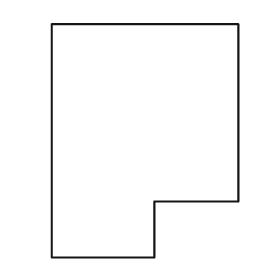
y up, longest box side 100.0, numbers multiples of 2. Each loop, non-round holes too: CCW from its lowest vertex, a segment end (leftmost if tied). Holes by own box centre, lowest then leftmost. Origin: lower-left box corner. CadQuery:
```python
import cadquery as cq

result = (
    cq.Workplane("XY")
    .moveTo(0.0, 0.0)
    .lineTo(44.0, 0.0)
    .lineTo(44.0, 24.0)
    .lineTo(80.0, 24.0)
    .lineTo(80.0, 100.0)
    .lineTo(0.0, 100.0)
    .close()
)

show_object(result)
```